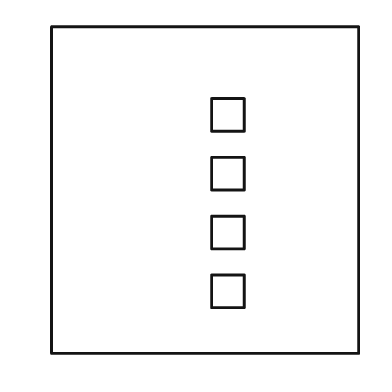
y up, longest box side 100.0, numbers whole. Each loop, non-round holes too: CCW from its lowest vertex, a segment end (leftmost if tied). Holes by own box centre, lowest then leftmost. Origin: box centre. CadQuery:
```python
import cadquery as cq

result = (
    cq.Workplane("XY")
    .moveTo(-47.0, -50.0)
    .lineTo(47.0, -50.0)
    .lineTo(47.0, 50.0)
    .lineTo(-47.0, 50.0)
    .close()
    .moveTo(2.0, -36.0)
    .lineTo(12.0, -36.0)
    .lineTo(12.0, -26.0)
    .lineTo(2.0, -26.0)
    .close()
    .moveTo(2.0, -18.0)
    .lineTo(12.0, -18.0)
    .lineTo(12.0, -8.0)
    .lineTo(2.0, -8.0)
    .close()
    .moveTo(2.0, 0.0)
    .lineTo(12.0, 0.0)
    .lineTo(12.0, 10.0)
    .lineTo(2.0, 10.0)
    .close()
    .moveTo(2.0, 18.0)
    .lineTo(12.0, 18.0)
    .lineTo(12.0, 28.0)
    .lineTo(2.0, 28.0)
    .close()
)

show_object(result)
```